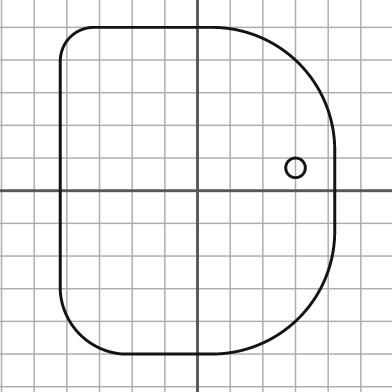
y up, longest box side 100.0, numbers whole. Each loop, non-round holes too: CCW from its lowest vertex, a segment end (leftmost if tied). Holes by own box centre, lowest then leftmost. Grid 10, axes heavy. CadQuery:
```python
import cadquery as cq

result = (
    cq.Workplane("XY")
    .moveTo(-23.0, -50.0)
    .lineTo(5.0, -50.0)
    .threePointArc((31.0, -39.0), (42.0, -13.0))
    .lineTo(42.0, 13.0)
    .threePointArc((31.0, 39.0), (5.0, 50.0))
    .lineTo(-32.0, 50.0)
    .threePointArc((-39.0, 47.0), (-42.0, 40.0))
    .lineTo(-42.0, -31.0)
    .threePointArc((-36.0, -44.0), (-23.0, -50.0))
    .close()
    .moveTo(30.0, 7.0)
    .circle(3.0)
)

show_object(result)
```